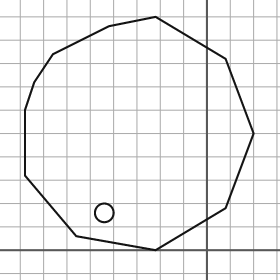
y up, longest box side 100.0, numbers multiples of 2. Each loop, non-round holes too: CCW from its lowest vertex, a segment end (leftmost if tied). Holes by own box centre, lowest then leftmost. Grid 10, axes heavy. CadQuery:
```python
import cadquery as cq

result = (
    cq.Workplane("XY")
    .moveTo(-22.0, 0.0)
    .lineTo(8.0, 18.0)
    .lineTo(20.0, 50.0)
    .lineTo(8.0, 82.0)
    .lineTo(-22.0, 100.0)
    .lineTo(-42.0, 96.0)
    .lineTo(-66.0, 84.0)
    .lineTo(-74.0, 72.0)
    .lineTo(-78.0, 60.0)
    .lineTo(-78.0, 32.0)
    .lineTo(-56.0, 6.0)
    .close()
    .moveTo(-44.0, 16.0)
    .circle(4.0)
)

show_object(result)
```